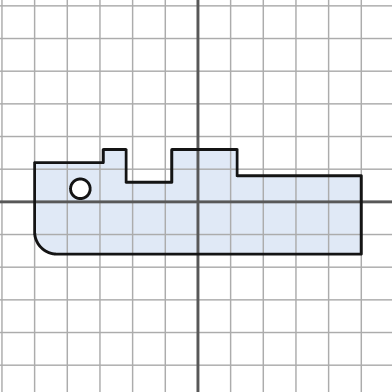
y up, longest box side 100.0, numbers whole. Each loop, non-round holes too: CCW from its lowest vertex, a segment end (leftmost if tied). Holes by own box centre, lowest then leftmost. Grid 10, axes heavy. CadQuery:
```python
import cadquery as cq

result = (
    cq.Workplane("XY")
    .moveTo(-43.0, -16.0)
    .lineTo(50.0, -16.0)
    .lineTo(50.0, 8.0)
    .lineTo(12.0, 8.0)
    .lineTo(12.0, 16.0)
    .lineTo(-8.0, 16.0)
    .lineTo(-8.0, 6.0)
    .lineTo(-22.0, 6.0)
    .lineTo(-22.0, 16.0)
    .lineTo(-29.0, 16.0)
    .lineTo(-29.0, 12.0)
    .lineTo(-50.0, 12.0)
    .lineTo(-50.0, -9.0)
    .threePointArc((-48.0, -14.0), (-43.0, -16.0))
    .close()
    .moveTo(-36.0, 4.0)
    .circle(3.0)
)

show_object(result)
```